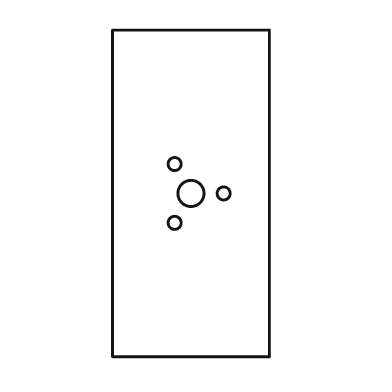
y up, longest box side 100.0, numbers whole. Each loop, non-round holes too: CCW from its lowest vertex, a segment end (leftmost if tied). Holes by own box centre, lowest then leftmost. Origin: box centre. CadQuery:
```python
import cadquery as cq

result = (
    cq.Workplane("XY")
    .moveTo(-24.0, -50.0)
    .lineTo(24.0, -50.0)
    .lineTo(24.0, 50.0)
    .lineTo(-24.0, 50.0)
    .close()
    .moveTo(-5.0, -9.0)
    .circle(2.0)
    .moveTo(0.0, 0.0)
    .circle(4.0)
    .moveTo(10.0, 0.0)
    .circle(2.0)
    .moveTo(-5.0, 9.0)
    .circle(2.0)
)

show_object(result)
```